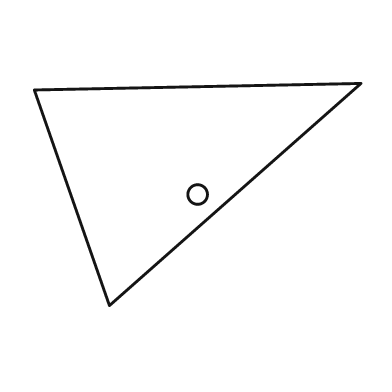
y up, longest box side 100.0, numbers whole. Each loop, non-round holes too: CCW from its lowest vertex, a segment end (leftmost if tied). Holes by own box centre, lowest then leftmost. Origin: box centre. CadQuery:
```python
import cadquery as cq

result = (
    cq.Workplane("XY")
    .moveTo(-27.0, -34.0)
    .lineTo(50.0, 34.0)
    .lineTo(-50.0, 32.0)
    .close()
    .moveTo(0.0, 0.0)
    .circle(3.0)
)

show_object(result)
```